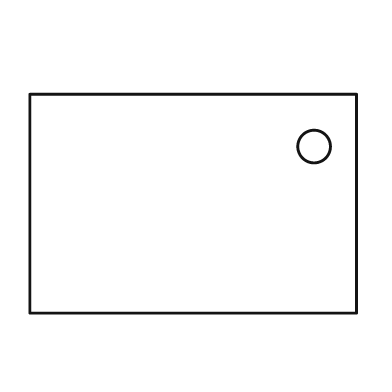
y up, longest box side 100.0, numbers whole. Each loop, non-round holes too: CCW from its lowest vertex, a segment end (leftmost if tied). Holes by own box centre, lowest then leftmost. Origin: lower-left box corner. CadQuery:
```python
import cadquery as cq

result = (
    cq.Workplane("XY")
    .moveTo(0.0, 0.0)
    .lineTo(100.0, 0.0)
    .lineTo(100.0, 67.0)
    .lineTo(0.0, 67.0)
    .close()
    .moveTo(87.0, 51.0)
    .circle(5.0)
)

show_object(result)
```